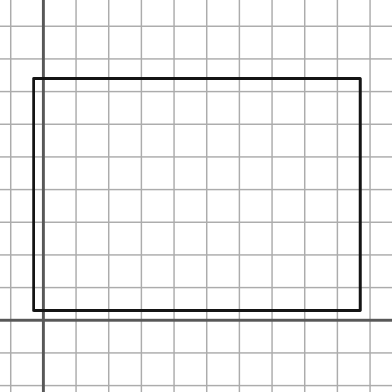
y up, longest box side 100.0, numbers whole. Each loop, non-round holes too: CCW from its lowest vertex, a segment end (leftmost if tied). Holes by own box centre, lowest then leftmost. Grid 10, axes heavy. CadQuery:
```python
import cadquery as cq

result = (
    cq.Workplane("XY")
    .moveTo(-3.0, 3.0)
    .lineTo(97.0, 3.0)
    .lineTo(97.0, 74.0)
    .lineTo(-3.0, 74.0)
    .close()
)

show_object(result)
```